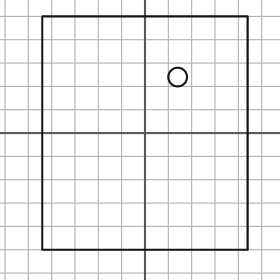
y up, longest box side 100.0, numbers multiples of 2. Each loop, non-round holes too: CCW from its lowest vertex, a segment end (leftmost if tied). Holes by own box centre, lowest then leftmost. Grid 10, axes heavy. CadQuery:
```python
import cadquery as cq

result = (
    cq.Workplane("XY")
    .moveTo(-44.0, -50.0)
    .lineTo(44.0, -50.0)
    .lineTo(44.0, 50.0)
    .lineTo(-44.0, 50.0)
    .close()
    .moveTo(14.0, 24.0)
    .circle(4.0)
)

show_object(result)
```